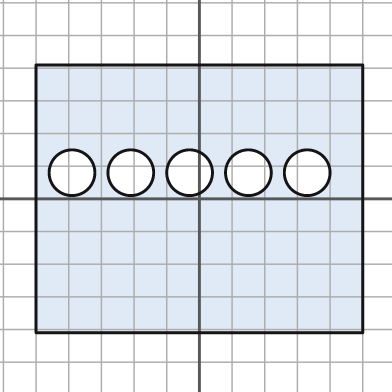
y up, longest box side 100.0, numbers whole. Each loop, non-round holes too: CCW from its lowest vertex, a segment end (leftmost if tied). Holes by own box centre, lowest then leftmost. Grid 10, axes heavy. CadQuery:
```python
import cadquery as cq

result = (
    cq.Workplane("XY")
    .moveTo(-50.0, -41.0)
    .lineTo(50.0, -41.0)
    .lineTo(50.0, 41.0)
    .lineTo(-50.0, 41.0)
    .close()
    .moveTo(-39.0, 8.0)
    .circle(7.0)
    .moveTo(-21.0, 8.0)
    .circle(7.0)
    .moveTo(-3.0, 8.0)
    .circle(7.0)
    .moveTo(15.0, 8.0)
    .circle(7.0)
    .moveTo(33.0, 8.0)
    .circle(7.0)
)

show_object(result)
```